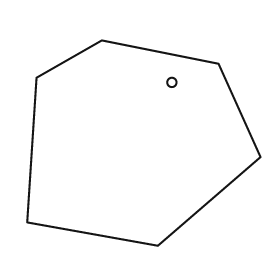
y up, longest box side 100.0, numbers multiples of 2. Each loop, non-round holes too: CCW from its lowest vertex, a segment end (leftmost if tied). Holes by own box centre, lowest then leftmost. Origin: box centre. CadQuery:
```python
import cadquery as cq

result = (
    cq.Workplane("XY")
    .moveTo(6.0, -44.0)
    .lineTo(50.0, -6.0)
    .lineTo(32.0, 34.0)
    .lineTo(-18.0, 44.0)
    .lineTo(-46.0, 28.0)
    .lineTo(-50.0, -34.0)
    .close()
    .moveTo(12.0, 26.0)
    .circle(2.0)
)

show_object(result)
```